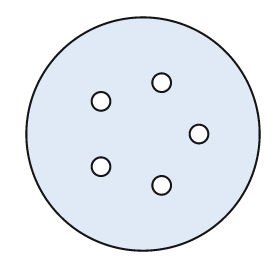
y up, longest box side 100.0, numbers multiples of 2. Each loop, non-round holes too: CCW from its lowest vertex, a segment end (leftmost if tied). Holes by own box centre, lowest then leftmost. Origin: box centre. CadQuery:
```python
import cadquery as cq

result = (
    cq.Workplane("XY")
    .moveTo(0.0, 0.0)
    .circle(50.0)
    .moveTo(8.0, -22.0)
    .circle(4.0)
    .moveTo(-18.0, -14.0)
    .circle(4.0)
    .moveTo(24.0, 0.0)
    .circle(4.0)
    .moveTo(-18.0, 14.0)
    .circle(4.0)
    .moveTo(8.0, 22.0)
    .circle(4.0)
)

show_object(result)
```